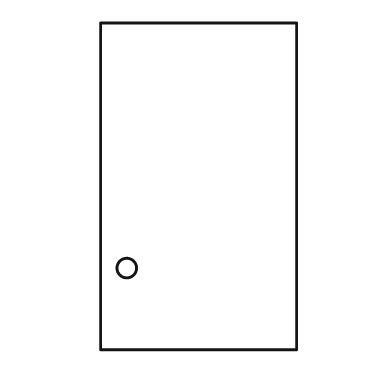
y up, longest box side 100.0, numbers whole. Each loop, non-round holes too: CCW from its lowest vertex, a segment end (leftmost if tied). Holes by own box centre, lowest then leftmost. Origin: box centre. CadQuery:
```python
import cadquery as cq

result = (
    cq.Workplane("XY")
    .moveTo(-30.0, -50.0)
    .lineTo(30.0, -50.0)
    .lineTo(30.0, 50.0)
    .lineTo(-30.0, 50.0)
    .close()
    .moveTo(-22.0, -25.0)
    .circle(3.0)
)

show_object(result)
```